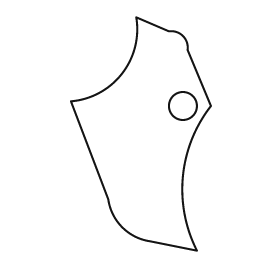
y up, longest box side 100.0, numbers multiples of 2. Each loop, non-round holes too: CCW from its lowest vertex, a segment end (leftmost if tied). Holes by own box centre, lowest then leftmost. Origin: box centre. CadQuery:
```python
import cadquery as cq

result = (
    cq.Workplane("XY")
    .moveTo(24.0, -50.0)
    .threePointArc((18.0, -18.0), (30.0, 12.0))
    .lineTo(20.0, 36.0)
    .threePointArc((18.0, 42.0), (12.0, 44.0))
    .lineTo(-2.0, 50.0)
    .threePointArc((-8.0, 26.0), (-30.0, 14.0))
    .lineTo(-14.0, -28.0)
    .threePointArc((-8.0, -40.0), (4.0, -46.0))
    .close()
    .moveTo(18.0, 12.0)
    .circle(6.0)
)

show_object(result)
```